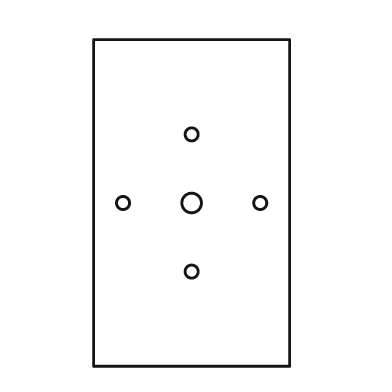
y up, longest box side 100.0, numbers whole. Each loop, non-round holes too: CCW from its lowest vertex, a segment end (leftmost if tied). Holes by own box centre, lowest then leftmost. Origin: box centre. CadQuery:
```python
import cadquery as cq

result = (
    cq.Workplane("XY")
    .moveTo(-30.0, -50.0)
    .lineTo(30.0, -50.0)
    .lineTo(30.0, 50.0)
    .lineTo(-30.0, 50.0)
    .close()
    .moveTo(0.0, -21.0)
    .circle(2.0)
    .moveTo(-21.0, 0.0)
    .circle(2.0)
    .moveTo(0.0, 0.0)
    .circle(3.0)
    .moveTo(21.0, 0.0)
    .circle(2.0)
    .moveTo(0.0, 21.0)
    .circle(2.0)
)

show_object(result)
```